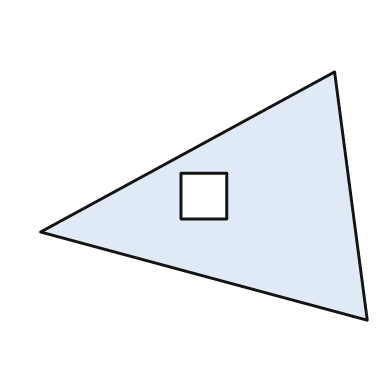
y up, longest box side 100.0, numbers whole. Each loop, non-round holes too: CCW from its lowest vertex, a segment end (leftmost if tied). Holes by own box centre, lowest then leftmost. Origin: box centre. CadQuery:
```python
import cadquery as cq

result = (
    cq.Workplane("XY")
    .moveTo(50.0, -38.0)
    .lineTo(40.0, 38.0)
    .lineTo(-50.0, -11.0)
    .close()
    .moveTo(-7.0, -7.0)
    .lineTo(7.0, -7.0)
    .lineTo(7.0, 7.0)
    .lineTo(-7.0, 7.0)
    .close()
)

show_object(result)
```